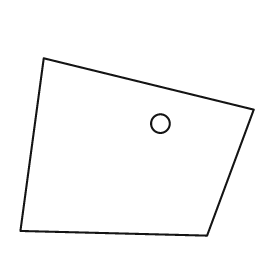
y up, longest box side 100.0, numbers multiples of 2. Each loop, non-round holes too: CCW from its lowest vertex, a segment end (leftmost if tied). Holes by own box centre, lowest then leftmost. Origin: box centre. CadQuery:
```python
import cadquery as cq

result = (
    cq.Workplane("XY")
    .moveTo(30.0, -38.0)
    .lineTo(50.0, 16.0)
    .lineTo(-40.0, 38.0)
    .lineTo(-50.0, -36.0)
    .close()
    .moveTo(10.0, 10.0)
    .circle(4.0)
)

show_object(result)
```